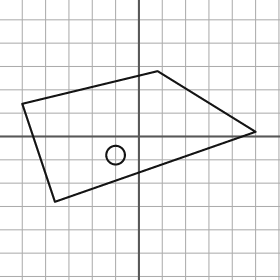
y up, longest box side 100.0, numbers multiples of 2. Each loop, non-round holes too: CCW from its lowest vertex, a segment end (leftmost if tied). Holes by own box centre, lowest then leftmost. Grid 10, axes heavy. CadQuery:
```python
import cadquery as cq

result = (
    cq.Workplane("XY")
    .moveTo(-36.0, -28.0)
    .lineTo(50.0, 2.0)
    .lineTo(8.0, 28.0)
    .lineTo(-50.0, 14.0)
    .close()
    .moveTo(-10.0, -8.0)
    .circle(4.0)
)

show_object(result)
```